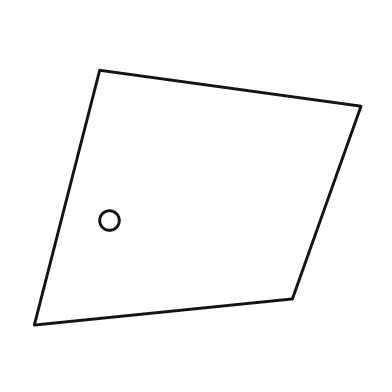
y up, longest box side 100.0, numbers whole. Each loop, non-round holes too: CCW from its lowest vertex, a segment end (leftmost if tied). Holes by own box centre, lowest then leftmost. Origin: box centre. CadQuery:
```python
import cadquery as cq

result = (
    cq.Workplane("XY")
    .moveTo(-50.0, -39.0)
    .lineTo(29.0, -31.0)
    .lineTo(50.0, 28.0)
    .lineTo(-30.0, 39.0)
    .close()
    .moveTo(-27.0, -7.0)
    .circle(3.0)
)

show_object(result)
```